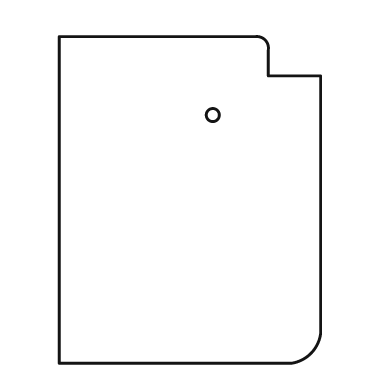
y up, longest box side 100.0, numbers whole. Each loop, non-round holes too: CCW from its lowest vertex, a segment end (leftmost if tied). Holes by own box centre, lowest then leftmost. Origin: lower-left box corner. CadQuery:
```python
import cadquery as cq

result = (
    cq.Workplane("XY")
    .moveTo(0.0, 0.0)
    .lineTo(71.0, 0.0)
    .threePointArc((77.0, 3.0), (80.0, 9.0))
    .lineTo(80.0, 88.0)
    .lineTo(64.0, 88.0)
    .lineTo(64.0, 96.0)
    .threePointArc((63.0, 99.0), (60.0, 100.0))
    .lineTo(0.0, 100.0)
    .close()
    .moveTo(47.0, 76.0)
    .circle(2.0)
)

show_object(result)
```